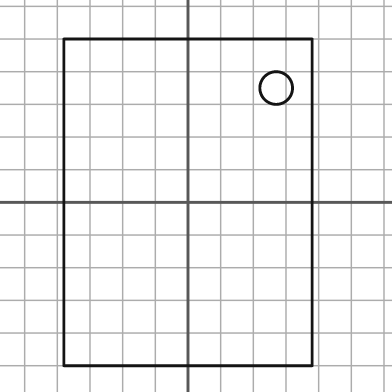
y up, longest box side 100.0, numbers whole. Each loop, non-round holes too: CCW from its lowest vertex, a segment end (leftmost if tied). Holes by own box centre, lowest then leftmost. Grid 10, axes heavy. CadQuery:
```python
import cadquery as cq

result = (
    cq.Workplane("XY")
    .moveTo(-38.0, -50.0)
    .lineTo(38.0, -50.0)
    .lineTo(38.0, 50.0)
    .lineTo(-38.0, 50.0)
    .close()
    .moveTo(27.0, 35.0)
    .circle(5.0)
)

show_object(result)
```